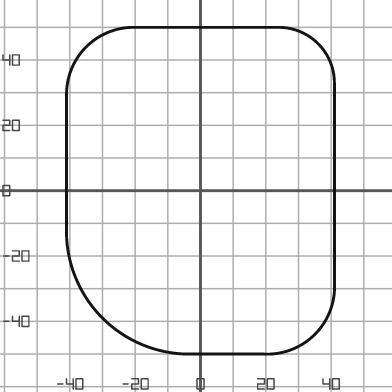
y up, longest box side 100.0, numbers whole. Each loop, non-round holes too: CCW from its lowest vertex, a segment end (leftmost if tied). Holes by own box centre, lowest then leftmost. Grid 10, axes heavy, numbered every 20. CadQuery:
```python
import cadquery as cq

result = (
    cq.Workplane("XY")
    .moveTo(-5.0, -50.0)
    .lineTo(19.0, -50.0)
    .threePointArc((35.0, -44.0), (41.0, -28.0))
    .lineTo(41.0, 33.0)
    .threePointArc((36.0, 45.0), (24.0, 50.0))
    .lineTo(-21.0, 50.0)
    .threePointArc((-35.0, 44.0), (-41.0, 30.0))
    .lineTo(-41.0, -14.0)
    .threePointArc((-30.0, -39.0), (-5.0, -50.0))
    .close()
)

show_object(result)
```